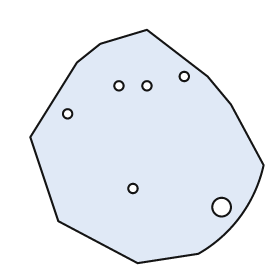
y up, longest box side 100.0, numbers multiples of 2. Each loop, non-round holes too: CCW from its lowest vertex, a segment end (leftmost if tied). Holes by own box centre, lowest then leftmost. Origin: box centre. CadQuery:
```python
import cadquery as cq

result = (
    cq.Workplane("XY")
    .moveTo(-4.0, -50.0)
    .lineTo(22.0, -46.0)
    .threePointArc((40.0, -30.0), (50.0, -8.0))
    .lineTo(36.0, 18.0)
    .lineTo(26.0, 30.0)
    .lineTo(0.0, 50.0)
    .lineTo(-20.0, 44.0)
    .lineTo(-30.0, 36.0)
    .lineTo(-50.0, 4.0)
    .lineTo(-38.0, -32.0)
    .close()
    .moveTo(32.0, -26.0)
    .circle(4.0)
    .moveTo(-6.0, -18.0)
    .circle(2.0)
    .moveTo(-34.0, 14.0)
    .circle(2.0)
    .moveTo(-12.0, 26.0)
    .circle(2.0)
    .moveTo(0.0, 26.0)
    .circle(2.0)
    .moveTo(16.0, 30.0)
    .circle(2.0)
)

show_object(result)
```